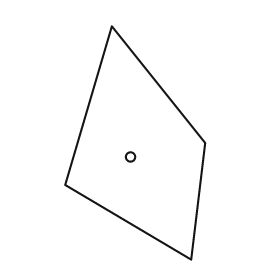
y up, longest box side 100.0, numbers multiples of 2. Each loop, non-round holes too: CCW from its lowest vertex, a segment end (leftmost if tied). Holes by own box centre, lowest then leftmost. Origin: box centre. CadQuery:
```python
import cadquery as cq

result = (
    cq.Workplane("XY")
    .moveTo(24.0, -50.0)
    .lineTo(30.0, 0.0)
    .lineTo(-10.0, 50.0)
    .lineTo(-30.0, -18.0)
    .close()
    .moveTo(-2.0, -6.0)
    .circle(2.0)
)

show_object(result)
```